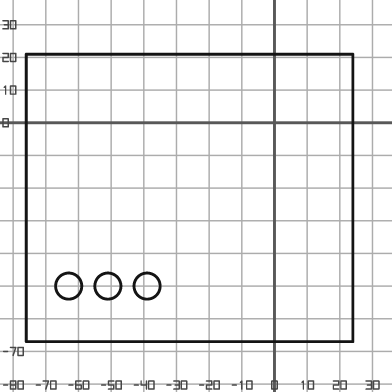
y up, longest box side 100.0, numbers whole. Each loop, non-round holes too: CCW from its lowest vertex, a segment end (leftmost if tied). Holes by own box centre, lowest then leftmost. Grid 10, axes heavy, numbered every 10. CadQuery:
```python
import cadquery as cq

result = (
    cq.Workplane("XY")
    .moveTo(-76.0, -67.0)
    .lineTo(24.0, -67.0)
    .lineTo(24.0, 21.0)
    .lineTo(-76.0, 21.0)
    .close()
    .moveTo(-63.0, -50.0)
    .circle(4.0)
    .moveTo(-51.0, -50.0)
    .circle(4.0)
    .moveTo(-39.0, -50.0)
    .circle(4.0)
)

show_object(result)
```